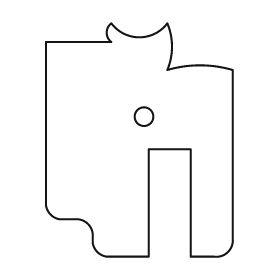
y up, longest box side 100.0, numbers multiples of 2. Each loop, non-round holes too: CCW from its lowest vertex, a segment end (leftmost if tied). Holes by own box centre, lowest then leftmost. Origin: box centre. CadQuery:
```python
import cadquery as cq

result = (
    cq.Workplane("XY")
    .moveTo(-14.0, -50.0)
    .lineTo(4.0, -50.0)
    .lineTo(4.0, -4.0)
    .lineTo(22.0, -4.0)
    .lineTo(22.0, -50.0)
    .lineTo(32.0, -50.0)
    .threePointArc((38.0, -48.0), (40.0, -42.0))
    .lineTo(40.0, 30.0)
    .threePointArc((26.0, 32.0), (12.0, 30.0))
    .threePointArc((14.0, 40.0), (12.0, 50.0))
    .threePointArc((0.0, 44.0), (-12.0, 50.0))
    .threePointArc((-14.0, 46.0), (-12.0, 42.0))
    .lineTo(-40.0, 42.0)
    .lineTo(-40.0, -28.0)
    .threePointArc((-38.0, -32.0), (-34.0, -34.0))
    .lineTo(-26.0, -34.0)
    .threePointArc((-22.0, -36.0), (-20.0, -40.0))
    .lineTo(-20.0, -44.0)
    .threePointArc((-18.0, -48.0), (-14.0, -50.0))
    .close()
    .moveTo(2.0, 10.0)
    .circle(4.0)
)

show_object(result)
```